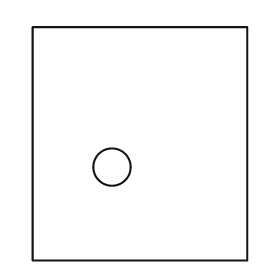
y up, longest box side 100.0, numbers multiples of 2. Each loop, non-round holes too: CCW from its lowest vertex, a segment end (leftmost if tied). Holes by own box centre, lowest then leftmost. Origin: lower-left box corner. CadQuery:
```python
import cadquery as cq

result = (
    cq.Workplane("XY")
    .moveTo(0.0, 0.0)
    .lineTo(92.0, 0.0)
    .lineTo(92.0, 100.0)
    .lineTo(0.0, 100.0)
    .close()
    .moveTo(34.0, 40.0)
    .circle(8.0)
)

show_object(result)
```